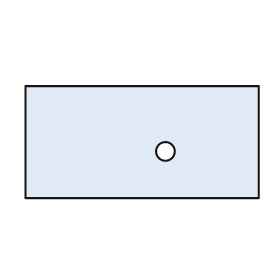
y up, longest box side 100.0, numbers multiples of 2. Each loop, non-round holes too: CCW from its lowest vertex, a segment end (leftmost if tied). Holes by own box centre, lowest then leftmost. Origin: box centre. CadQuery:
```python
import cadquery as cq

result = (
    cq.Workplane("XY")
    .moveTo(-50.0, -24.0)
    .lineTo(50.0, -24.0)
    .lineTo(50.0, 24.0)
    .lineTo(-50.0, 24.0)
    .close()
    .moveTo(10.0, -4.0)
    .circle(4.0)
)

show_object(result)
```